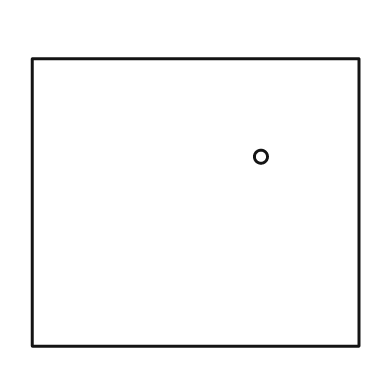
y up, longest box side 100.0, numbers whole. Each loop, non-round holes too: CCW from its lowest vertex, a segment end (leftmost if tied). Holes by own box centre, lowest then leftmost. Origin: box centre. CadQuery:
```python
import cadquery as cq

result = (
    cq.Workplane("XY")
    .moveTo(-50.0, -44.0)
    .lineTo(50.0, -44.0)
    .lineTo(50.0, 44.0)
    .lineTo(-50.0, 44.0)
    .close()
    .moveTo(20.0, 14.0)
    .circle(2.0)
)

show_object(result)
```